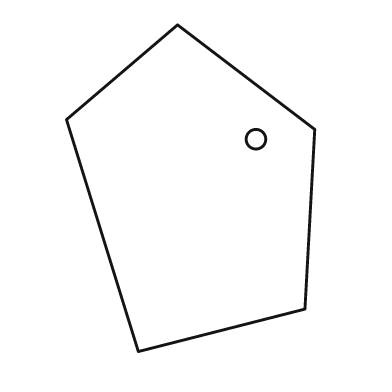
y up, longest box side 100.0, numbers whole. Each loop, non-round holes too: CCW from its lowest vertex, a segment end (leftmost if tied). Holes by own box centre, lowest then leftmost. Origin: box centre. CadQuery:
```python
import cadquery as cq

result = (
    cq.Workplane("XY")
    .moveTo(-16.0, -50.0)
    .lineTo(35.0, -37.0)
    .lineTo(38.0, 18.0)
    .lineTo(-4.0, 50.0)
    .lineTo(-38.0, 21.0)
    .close()
    .moveTo(20.0, 15.0)
    .circle(3.0)
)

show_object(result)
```